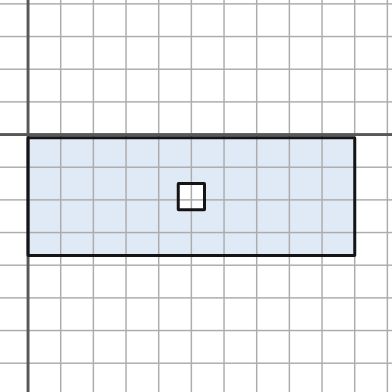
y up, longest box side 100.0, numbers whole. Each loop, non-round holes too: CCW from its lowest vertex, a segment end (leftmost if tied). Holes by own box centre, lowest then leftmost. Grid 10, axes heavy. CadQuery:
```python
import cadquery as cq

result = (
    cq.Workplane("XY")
    .moveTo(0.0, -37.0)
    .lineTo(100.0, -37.0)
    .lineTo(100.0, -1.0)
    .lineTo(0.0, -1.0)
    .close()
    .moveTo(46.0, -23.0)
    .lineTo(54.0, -23.0)
    .lineTo(54.0, -15.0)
    .lineTo(46.0, -15.0)
    .close()
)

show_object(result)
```